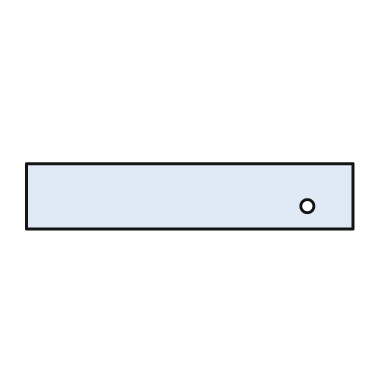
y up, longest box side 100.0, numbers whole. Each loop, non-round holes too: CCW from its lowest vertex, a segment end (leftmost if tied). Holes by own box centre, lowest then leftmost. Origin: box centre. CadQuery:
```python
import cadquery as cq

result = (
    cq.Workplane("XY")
    .moveTo(-50.0, -10.0)
    .lineTo(50.0, -10.0)
    .lineTo(50.0, 10.0)
    .lineTo(-50.0, 10.0)
    .close()
    .moveTo(36.0, -3.0)
    .circle(2.0)
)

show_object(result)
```